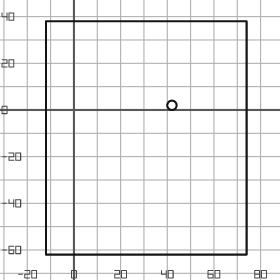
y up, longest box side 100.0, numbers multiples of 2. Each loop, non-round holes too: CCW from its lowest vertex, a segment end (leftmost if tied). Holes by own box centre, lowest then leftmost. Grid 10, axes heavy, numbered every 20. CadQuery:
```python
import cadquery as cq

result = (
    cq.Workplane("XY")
    .moveTo(-12.0, -62.0)
    .lineTo(74.0, -62.0)
    .lineTo(74.0, 38.0)
    .lineTo(-12.0, 38.0)
    .close()
    .moveTo(42.0, 2.0)
    .circle(2.0)
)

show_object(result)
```